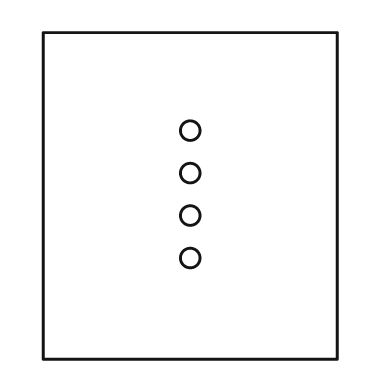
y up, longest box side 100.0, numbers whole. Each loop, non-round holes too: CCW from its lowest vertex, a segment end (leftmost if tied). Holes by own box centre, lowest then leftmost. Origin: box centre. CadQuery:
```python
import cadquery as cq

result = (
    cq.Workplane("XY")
    .moveTo(-45.0, -50.0)
    .lineTo(45.0, -50.0)
    .lineTo(45.0, 50.0)
    .lineTo(-45.0, 50.0)
    .close()
    .moveTo(0.0, -19.0)
    .circle(3.0)
    .moveTo(0.0, -6.0)
    .circle(3.0)
    .moveTo(0.0, 7.0)
    .circle(3.0)
    .moveTo(0.0, 20.0)
    .circle(3.0)
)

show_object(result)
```